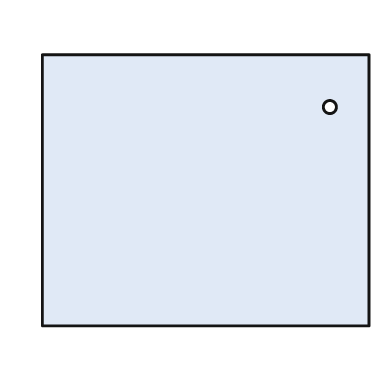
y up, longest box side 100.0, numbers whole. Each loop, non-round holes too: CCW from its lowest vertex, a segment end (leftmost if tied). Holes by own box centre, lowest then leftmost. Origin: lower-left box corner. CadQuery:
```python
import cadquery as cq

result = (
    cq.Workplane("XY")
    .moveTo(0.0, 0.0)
    .lineTo(100.0, 0.0)
    .lineTo(100.0, 83.0)
    .lineTo(0.0, 83.0)
    .close()
    .moveTo(88.0, 67.0)
    .circle(2.0)
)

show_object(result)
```